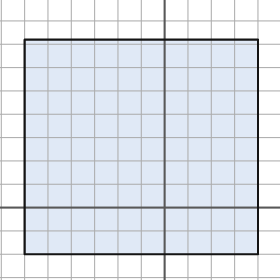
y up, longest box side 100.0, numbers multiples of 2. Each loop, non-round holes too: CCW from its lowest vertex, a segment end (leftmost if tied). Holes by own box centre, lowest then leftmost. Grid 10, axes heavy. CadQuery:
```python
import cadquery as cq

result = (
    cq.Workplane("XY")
    .moveTo(-60.0, -20.0)
    .lineTo(40.0, -20.0)
    .lineTo(40.0, 72.0)
    .lineTo(-60.0, 72.0)
    .close()
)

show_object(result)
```